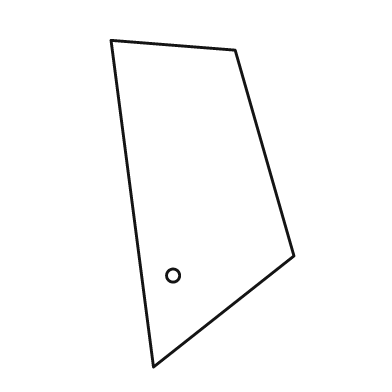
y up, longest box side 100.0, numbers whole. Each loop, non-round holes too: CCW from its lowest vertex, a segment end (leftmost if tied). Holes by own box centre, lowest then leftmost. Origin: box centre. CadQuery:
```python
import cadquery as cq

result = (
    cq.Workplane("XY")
    .moveTo(-15.0, -50.0)
    .lineTo(28.0, -16.0)
    .lineTo(10.0, 47.0)
    .lineTo(-28.0, 50.0)
    .close()
    .moveTo(-9.0, -22.0)
    .circle(2.0)
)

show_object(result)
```